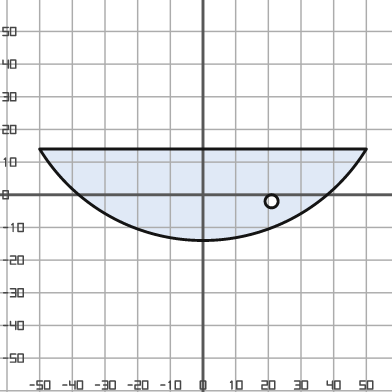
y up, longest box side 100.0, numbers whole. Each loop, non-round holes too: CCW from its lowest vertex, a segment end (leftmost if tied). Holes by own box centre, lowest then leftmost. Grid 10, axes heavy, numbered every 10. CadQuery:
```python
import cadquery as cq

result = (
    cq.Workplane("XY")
    .moveTo(-50.0, 14.0)
    .threePointArc((0.0, -14.0), (50.0, 14.0))
    .close()
    .moveTo(21.0, -2.0)
    .circle(2.0)
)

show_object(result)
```